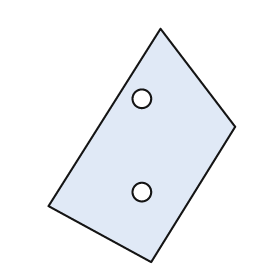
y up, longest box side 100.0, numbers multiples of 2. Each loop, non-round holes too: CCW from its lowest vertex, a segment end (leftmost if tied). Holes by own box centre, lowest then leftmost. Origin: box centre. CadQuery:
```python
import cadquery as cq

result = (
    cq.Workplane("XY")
    .moveTo(4.0, -50.0)
    .lineTo(40.0, 8.0)
    .lineTo(8.0, 50.0)
    .lineTo(-40.0, -26.0)
    .close()
    .moveTo(0.0, -20.0)
    .circle(4.0)
    .moveTo(0.0, 20.0)
    .circle(4.0)
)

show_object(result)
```